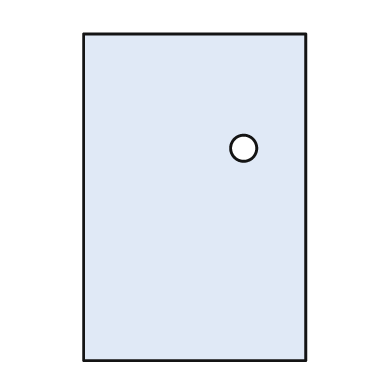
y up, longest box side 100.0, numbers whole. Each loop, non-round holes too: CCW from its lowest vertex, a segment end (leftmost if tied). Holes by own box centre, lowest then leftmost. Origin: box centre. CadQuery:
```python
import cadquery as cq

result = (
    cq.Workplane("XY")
    .moveTo(-34.0, -50.0)
    .lineTo(34.0, -50.0)
    .lineTo(34.0, 50.0)
    .lineTo(-34.0, 50.0)
    .close()
    .moveTo(15.0, 15.0)
    .circle(4.0)
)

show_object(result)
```